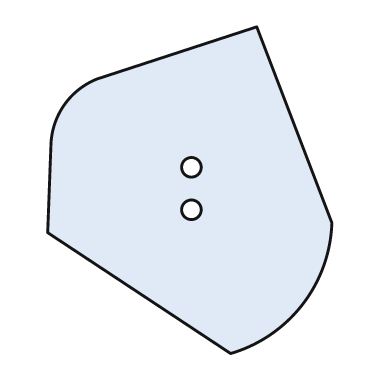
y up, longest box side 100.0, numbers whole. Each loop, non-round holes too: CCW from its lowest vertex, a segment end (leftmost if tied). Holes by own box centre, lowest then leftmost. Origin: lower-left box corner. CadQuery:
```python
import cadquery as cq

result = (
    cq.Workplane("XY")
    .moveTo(56.0, 0.0)
    .threePointArc((78.0, 15.0), (87.0, 40.0))
    .lineTo(64.0, 100.0)
    .lineTo(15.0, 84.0)
    .threePointArc((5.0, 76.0), (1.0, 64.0))
    .lineTo(0.0, 37.0)
    .close()
    .moveTo(44.0, 44.0)
    .circle(3.0)
    .moveTo(44.0, 57.0)
    .circle(3.0)
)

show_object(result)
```